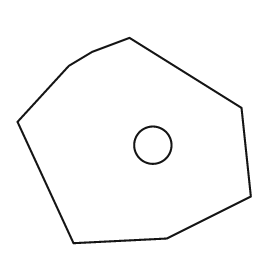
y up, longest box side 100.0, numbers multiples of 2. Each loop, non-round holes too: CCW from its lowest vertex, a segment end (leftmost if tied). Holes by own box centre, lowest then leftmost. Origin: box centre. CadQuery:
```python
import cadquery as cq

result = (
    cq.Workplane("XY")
    .moveTo(-26.0, -44.0)
    .lineTo(14.0, -42.0)
    .lineTo(50.0, -24.0)
    .lineTo(46.0, 14.0)
    .lineTo(-2.0, 44.0)
    .lineTo(-18.0, 38.0)
    .lineTo(-28.0, 32.0)
    .lineTo(-50.0, 8.0)
    .close()
    .moveTo(8.0, -2.0)
    .circle(8.0)
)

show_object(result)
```